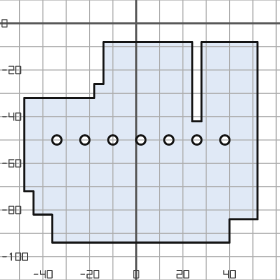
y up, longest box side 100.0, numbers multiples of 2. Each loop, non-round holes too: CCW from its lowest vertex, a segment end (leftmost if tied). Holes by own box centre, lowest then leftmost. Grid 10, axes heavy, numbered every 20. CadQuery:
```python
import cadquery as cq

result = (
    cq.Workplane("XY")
    .moveTo(-36.0, -94.0)
    .lineTo(40.0, -94.0)
    .lineTo(40.0, -84.0)
    .lineTo(52.0, -84.0)
    .lineTo(52.0, -8.0)
    .lineTo(28.0, -8.0)
    .lineTo(28.0, -42.0)
    .lineTo(24.0, -42.0)
    .lineTo(24.0, -8.0)
    .lineTo(-14.0, -8.0)
    .lineTo(-14.0, -26.0)
    .lineTo(-18.0, -26.0)
    .lineTo(-18.0, -32.0)
    .lineTo(-48.0, -32.0)
    .lineTo(-48.0, -72.0)
    .lineTo(-44.0, -72.0)
    .lineTo(-44.0, -82.0)
    .lineTo(-36.0, -82.0)
    .close()
    .moveTo(-34.0, -50.0)
    .circle(2.0)
    .moveTo(-22.0, -50.0)
    .circle(2.0)
    .moveTo(-10.0, -50.0)
    .circle(2.0)
    .moveTo(2.0, -50.0)
    .circle(2.0)
    .moveTo(14.0, -50.0)
    .circle(2.0)
    .moveTo(26.0, -50.0)
    .circle(2.0)
    .moveTo(38.0, -50.0)
    .circle(2.0)
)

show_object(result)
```